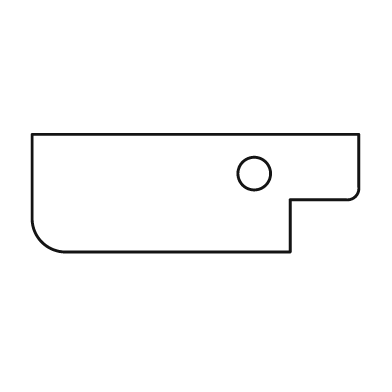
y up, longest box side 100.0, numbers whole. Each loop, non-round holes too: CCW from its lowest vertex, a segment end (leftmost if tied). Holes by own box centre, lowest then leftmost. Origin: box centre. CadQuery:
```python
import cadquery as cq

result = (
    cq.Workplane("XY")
    .moveTo(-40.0, -18.0)
    .lineTo(29.0, -18.0)
    .lineTo(29.0, -2.0)
    .lineTo(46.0, -2.0)
    .threePointArc((49.0, -1.0), (50.0, 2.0))
    .lineTo(50.0, 18.0)
    .lineTo(-50.0, 18.0)
    .lineTo(-50.0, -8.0)
    .threePointArc((-47.0, -15.0), (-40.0, -18.0))
    .close()
    .moveTo(18.0, 6.0)
    .circle(5.0)
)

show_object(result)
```